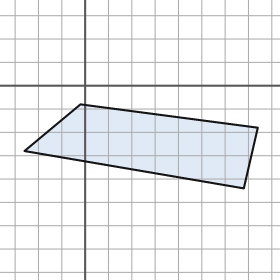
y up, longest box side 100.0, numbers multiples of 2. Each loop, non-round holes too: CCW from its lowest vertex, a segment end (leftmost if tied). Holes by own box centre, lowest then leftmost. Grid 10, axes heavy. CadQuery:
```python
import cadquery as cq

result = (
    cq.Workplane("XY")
    .moveTo(68.0, -44.0)
    .lineTo(74.0, -18.0)
    .lineTo(-2.0, -8.0)
    .lineTo(-26.0, -28.0)
    .close()
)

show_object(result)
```